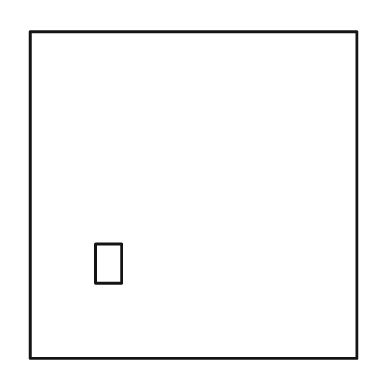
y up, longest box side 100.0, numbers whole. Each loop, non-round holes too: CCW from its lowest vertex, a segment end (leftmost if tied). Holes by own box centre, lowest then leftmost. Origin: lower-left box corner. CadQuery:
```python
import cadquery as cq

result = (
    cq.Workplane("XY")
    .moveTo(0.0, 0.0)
    .lineTo(100.0, 0.0)
    .lineTo(100.0, 100.0)
    .lineTo(0.0, 100.0)
    .close()
    .moveTo(20.0, 23.0)
    .lineTo(28.0, 23.0)
    .lineTo(28.0, 35.0)
    .lineTo(20.0, 35.0)
    .close()
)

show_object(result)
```